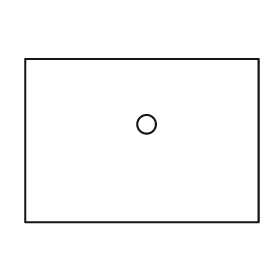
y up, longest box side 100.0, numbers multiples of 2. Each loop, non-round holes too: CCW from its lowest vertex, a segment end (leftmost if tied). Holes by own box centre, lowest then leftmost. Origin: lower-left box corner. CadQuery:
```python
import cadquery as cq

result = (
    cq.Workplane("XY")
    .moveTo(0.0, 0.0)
    .lineTo(100.0, 0.0)
    .lineTo(100.0, 70.0)
    .lineTo(0.0, 70.0)
    .close()
    .moveTo(52.0, 42.0)
    .circle(4.0)
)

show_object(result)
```